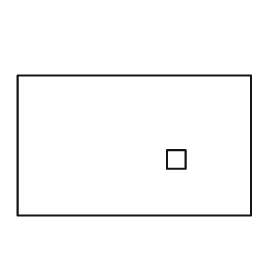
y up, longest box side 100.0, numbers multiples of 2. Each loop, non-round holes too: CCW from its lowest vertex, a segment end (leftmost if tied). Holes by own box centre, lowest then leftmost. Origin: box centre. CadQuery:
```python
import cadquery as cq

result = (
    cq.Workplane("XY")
    .moveTo(-50.0, -30.0)
    .lineTo(50.0, -30.0)
    .lineTo(50.0, 30.0)
    .lineTo(-50.0, 30.0)
    .close()
    .moveTo(14.0, -10.0)
    .lineTo(22.0, -10.0)
    .lineTo(22.0, -2.0)
    .lineTo(14.0, -2.0)
    .close()
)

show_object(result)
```